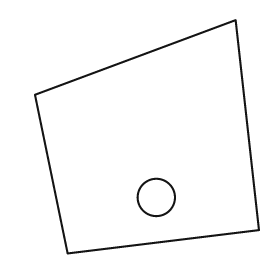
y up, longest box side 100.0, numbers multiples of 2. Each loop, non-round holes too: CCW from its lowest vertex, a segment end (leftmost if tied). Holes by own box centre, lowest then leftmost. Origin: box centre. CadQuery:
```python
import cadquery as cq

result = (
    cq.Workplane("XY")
    .moveTo(-34.0, -50.0)
    .lineTo(48.0, -40.0)
    .lineTo(38.0, 50.0)
    .lineTo(-48.0, 18.0)
    .close()
    .moveTo(4.0, -26.0)
    .circle(8.0)
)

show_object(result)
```